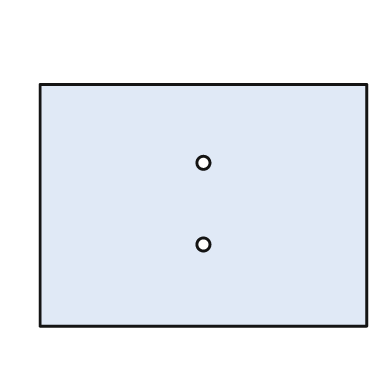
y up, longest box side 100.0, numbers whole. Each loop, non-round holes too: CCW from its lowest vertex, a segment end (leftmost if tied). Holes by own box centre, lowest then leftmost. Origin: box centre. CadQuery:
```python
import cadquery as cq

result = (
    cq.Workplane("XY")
    .moveTo(-50.0, -37.0)
    .lineTo(50.0, -37.0)
    .lineTo(50.0, 37.0)
    .lineTo(-50.0, 37.0)
    .close()
    .moveTo(0.0, -12.0)
    .circle(2.0)
    .moveTo(0.0, 13.0)
    .circle(2.0)
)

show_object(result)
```